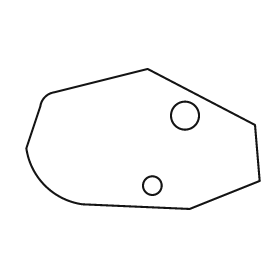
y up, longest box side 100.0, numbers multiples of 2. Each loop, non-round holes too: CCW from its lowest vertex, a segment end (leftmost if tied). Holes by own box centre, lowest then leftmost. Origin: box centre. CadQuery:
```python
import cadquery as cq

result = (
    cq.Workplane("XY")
    .moveTo(20.0, -30.0)
    .lineTo(50.0, -18.0)
    .lineTo(48.0, 6.0)
    .lineTo(2.0, 30.0)
    .lineTo(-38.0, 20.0)
    .threePointArc((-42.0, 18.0), (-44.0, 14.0))
    .lineTo(-50.0, -4.0)
    .threePointArc((-42.0, -20.0), (-26.0, -28.0))
    .close()
    .moveTo(4.0, -20.0)
    .circle(4.0)
    .moveTo(18.0, 10.0)
    .circle(6.0)
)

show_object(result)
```